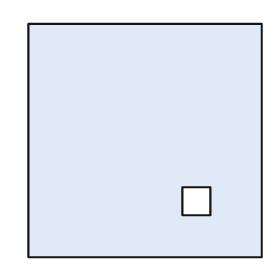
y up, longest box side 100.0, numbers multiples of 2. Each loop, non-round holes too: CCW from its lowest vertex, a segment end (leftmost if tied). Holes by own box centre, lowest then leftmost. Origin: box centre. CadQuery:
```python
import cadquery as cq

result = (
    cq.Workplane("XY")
    .moveTo(-50.0, -50.0)
    .lineTo(50.0, -50.0)
    .lineTo(50.0, 50.0)
    .lineTo(-50.0, 50.0)
    .close()
    .moveTo(16.0, -32.0)
    .lineTo(28.0, -32.0)
    .lineTo(28.0, -20.0)
    .lineTo(16.0, -20.0)
    .close()
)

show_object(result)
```